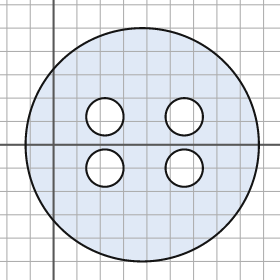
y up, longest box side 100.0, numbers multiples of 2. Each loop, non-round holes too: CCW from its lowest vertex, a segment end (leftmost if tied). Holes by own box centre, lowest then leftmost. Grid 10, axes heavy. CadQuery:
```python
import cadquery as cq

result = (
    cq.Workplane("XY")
    .moveTo(38.0, 0.0)
    .circle(50.0)
    .moveTo(22.0, -10.0)
    .circle(8.0)
    .moveTo(56.0, -10.0)
    .circle(8.0)
    .moveTo(22.0, 12.0)
    .circle(8.0)
    .moveTo(56.0, 12.0)
    .circle(8.0)
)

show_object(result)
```